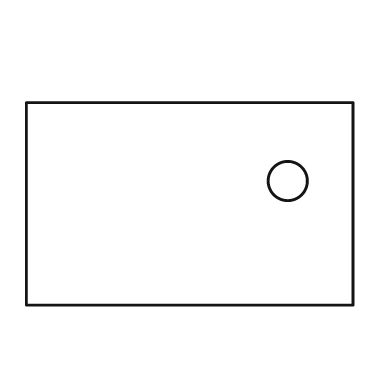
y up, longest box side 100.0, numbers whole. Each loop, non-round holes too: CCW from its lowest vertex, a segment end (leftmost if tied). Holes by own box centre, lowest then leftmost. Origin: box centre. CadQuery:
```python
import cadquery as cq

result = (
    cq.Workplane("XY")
    .moveTo(-50.0, -31.0)
    .lineTo(50.0, -31.0)
    .lineTo(50.0, 31.0)
    .lineTo(-50.0, 31.0)
    .close()
    .moveTo(30.0, 7.0)
    .circle(6.0)
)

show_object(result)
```